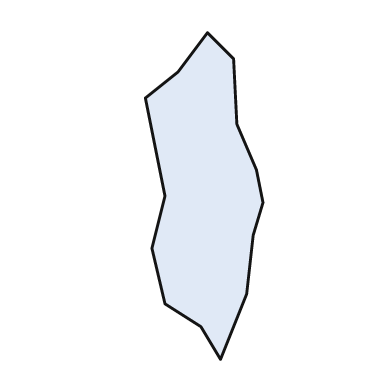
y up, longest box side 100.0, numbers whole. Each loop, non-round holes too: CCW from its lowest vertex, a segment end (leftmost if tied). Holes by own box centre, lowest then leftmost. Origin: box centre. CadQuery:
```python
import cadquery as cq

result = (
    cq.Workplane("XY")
    .moveTo(5.0, -50.0)
    .lineTo(13.0, -30.0)
    .lineTo(15.0, -12.0)
    .lineTo(18.0, -2.0)
    .lineTo(16.0, 8.0)
    .lineTo(10.0, 22.0)
    .lineTo(9.0, 42.0)
    .lineTo(1.0, 50.0)
    .lineTo(-8.0, 38.0)
    .lineTo(-18.0, 30.0)
    .lineTo(-12.0, 0.0)
    .lineTo(-16.0, -16.0)
    .lineTo(-12.0, -33.0)
    .lineTo(-1.0, -40.0)
    .close()
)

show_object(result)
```